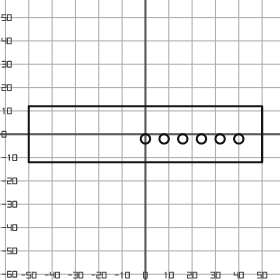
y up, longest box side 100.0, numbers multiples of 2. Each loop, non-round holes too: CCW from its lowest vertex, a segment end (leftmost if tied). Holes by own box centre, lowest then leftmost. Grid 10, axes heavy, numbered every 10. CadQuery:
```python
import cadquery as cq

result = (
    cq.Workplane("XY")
    .moveTo(-50.0, -12.0)
    .lineTo(50.0, -12.0)
    .lineTo(50.0, 12.0)
    .lineTo(-50.0, 12.0)
    .close()
    .moveTo(0.0, -2.0)
    .circle(2.0)
    .moveTo(8.0, -2.0)
    .circle(2.0)
    .moveTo(16.0, -2.0)
    .circle(2.0)
    .moveTo(24.0, -2.0)
    .circle(2.0)
    .moveTo(32.0, -2.0)
    .circle(2.0)
    .moveTo(40.0, -2.0)
    .circle(2.0)
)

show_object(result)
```